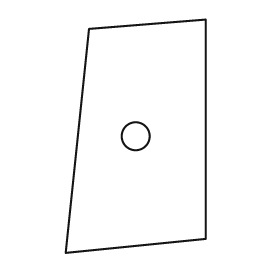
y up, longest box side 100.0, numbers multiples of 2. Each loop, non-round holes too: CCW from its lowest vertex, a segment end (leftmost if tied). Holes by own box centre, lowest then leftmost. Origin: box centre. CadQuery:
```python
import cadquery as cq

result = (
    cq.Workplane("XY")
    .moveTo(-30.0, -50.0)
    .lineTo(30.0, -44.0)
    .lineTo(30.0, 50.0)
    .lineTo(-20.0, 46.0)
    .close()
    .moveTo(0.0, 0.0)
    .circle(6.0)
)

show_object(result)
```